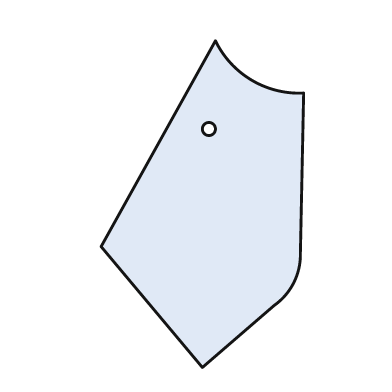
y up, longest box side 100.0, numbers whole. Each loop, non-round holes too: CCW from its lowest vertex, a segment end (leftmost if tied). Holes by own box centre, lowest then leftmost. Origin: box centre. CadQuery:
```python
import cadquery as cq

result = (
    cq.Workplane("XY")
    .moveTo(0.0, -50.0)
    .lineTo(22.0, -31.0)
    .threePointArc((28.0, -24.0), (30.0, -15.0))
    .lineTo(31.0, 34.0)
    .threePointArc((15.0, 38.0), (4.0, 50.0))
    .lineTo(-31.0, -13.0)
    .close()
    .moveTo(2.0, 23.0)
    .circle(2.0)
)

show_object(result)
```